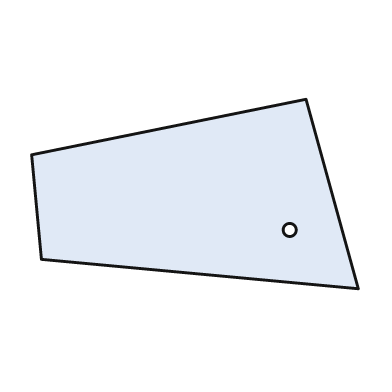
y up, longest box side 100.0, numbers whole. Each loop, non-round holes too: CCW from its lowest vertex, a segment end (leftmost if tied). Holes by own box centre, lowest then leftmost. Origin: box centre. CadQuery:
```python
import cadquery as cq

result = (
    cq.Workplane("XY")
    .moveTo(50.0, -29.0)
    .lineTo(34.0, 29.0)
    .lineTo(-50.0, 12.0)
    .lineTo(-47.0, -20.0)
    .close()
    .moveTo(29.0, -11.0)
    .circle(2.0)
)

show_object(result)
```